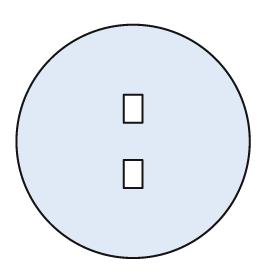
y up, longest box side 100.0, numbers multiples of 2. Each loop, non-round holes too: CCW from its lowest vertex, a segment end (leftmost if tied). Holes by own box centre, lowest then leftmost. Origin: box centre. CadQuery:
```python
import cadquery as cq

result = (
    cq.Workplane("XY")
    .moveTo(0.0, 0.0)
    .circle(50.0)
    .moveTo(-4.0, -20.0)
    .lineTo(4.0, -20.0)
    .lineTo(4.0, -8.0)
    .lineTo(-4.0, -8.0)
    .close()
    .moveTo(-4.0, 8.0)
    .lineTo(4.0, 8.0)
    .lineTo(4.0, 20.0)
    .lineTo(-4.0, 20.0)
    .close()
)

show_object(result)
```